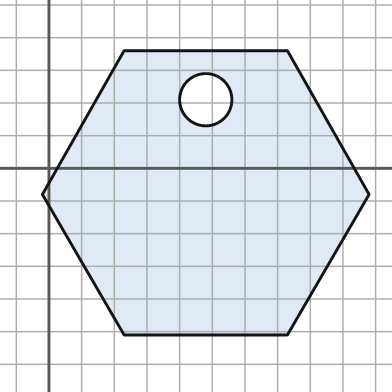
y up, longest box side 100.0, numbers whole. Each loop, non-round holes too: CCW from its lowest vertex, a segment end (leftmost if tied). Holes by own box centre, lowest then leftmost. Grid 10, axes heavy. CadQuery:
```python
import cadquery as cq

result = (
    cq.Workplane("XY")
    .moveTo(23.0, -51.0)
    .lineTo(73.0, -51.0)
    .lineTo(98.0, -8.0)
    .lineTo(73.0, 36.0)
    .lineTo(23.0, 36.0)
    .lineTo(-2.0, -8.0)
    .close()
    .moveTo(48.0, 21.0)
    .circle(8.0)
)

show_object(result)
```